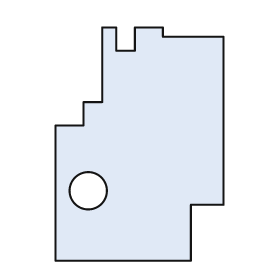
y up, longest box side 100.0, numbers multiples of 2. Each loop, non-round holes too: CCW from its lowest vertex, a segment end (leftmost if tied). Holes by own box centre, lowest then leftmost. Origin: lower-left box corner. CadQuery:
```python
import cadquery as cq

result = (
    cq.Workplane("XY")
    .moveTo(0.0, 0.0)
    .lineTo(58.0, 0.0)
    .lineTo(58.0, 24.0)
    .lineTo(72.0, 24.0)
    .lineTo(72.0, 96.0)
    .lineTo(46.0, 96.0)
    .lineTo(46.0, 100.0)
    .lineTo(34.0, 100.0)
    .lineTo(34.0, 90.0)
    .lineTo(26.0, 90.0)
    .lineTo(26.0, 100.0)
    .lineTo(20.0, 100.0)
    .lineTo(20.0, 68.0)
    .lineTo(12.0, 68.0)
    .lineTo(12.0, 58.0)
    .lineTo(0.0, 58.0)
    .close()
    .moveTo(14.0, 30.0)
    .circle(8.0)
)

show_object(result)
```